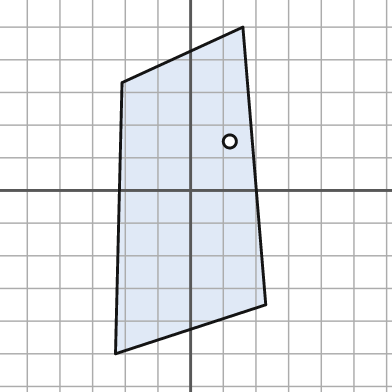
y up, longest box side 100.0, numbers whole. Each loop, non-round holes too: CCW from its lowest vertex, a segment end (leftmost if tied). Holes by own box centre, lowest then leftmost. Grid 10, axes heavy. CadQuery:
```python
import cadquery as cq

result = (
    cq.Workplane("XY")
    .moveTo(-23.0, -50.0)
    .lineTo(23.0, -35.0)
    .lineTo(16.0, 50.0)
    .lineTo(-21.0, 33.0)
    .close()
    .moveTo(12.0, 15.0)
    .circle(2.0)
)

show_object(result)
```